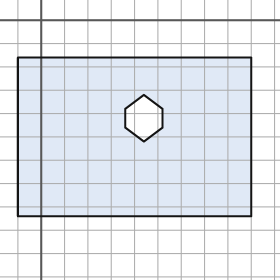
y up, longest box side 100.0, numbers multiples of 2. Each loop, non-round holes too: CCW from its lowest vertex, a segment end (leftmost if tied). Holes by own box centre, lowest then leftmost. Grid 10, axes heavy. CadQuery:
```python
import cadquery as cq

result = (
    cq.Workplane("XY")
    .moveTo(-10.0, -84.0)
    .lineTo(90.0, -84.0)
    .lineTo(90.0, -16.0)
    .lineTo(-10.0, -16.0)
    .close()
    .moveTo(44.0, -52.0)
    .lineTo(52.0, -46.0)
    .lineTo(52.0, -38.0)
    .lineTo(44.0, -32.0)
    .lineTo(36.0, -38.0)
    .lineTo(36.0, -46.0)
    .close()
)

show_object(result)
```